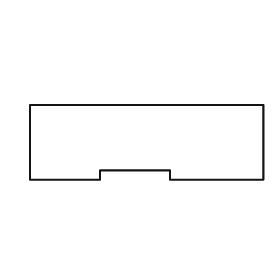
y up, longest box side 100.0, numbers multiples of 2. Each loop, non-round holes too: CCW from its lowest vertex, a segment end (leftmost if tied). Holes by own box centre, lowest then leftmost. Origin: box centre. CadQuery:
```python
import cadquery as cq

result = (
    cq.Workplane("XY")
    .moveTo(-50.0, -16.0)
    .lineTo(-20.0, -16.0)
    .lineTo(-20.0, -12.0)
    .lineTo(10.0, -12.0)
    .lineTo(10.0, -16.0)
    .lineTo(50.0, -16.0)
    .lineTo(50.0, 16.0)
    .lineTo(-50.0, 16.0)
    .close()
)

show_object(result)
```